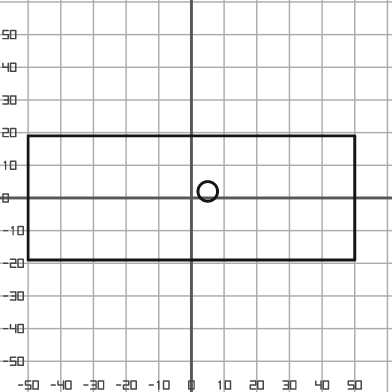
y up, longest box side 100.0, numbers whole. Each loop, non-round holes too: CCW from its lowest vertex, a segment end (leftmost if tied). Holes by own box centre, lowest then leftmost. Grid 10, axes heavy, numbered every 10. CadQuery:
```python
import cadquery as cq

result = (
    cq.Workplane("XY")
    .moveTo(-50.0, -19.0)
    .lineTo(50.0, -19.0)
    .lineTo(50.0, 19.0)
    .lineTo(-50.0, 19.0)
    .close()
    .moveTo(5.0, 2.0)
    .circle(3.0)
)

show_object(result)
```